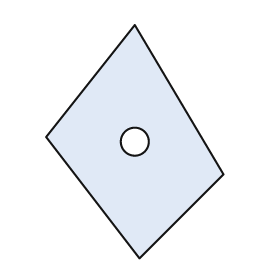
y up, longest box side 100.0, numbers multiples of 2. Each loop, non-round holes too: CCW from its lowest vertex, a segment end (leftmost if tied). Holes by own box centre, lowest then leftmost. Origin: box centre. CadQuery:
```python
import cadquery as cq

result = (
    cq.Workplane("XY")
    .moveTo(2.0, -50.0)
    .lineTo(38.0, -14.0)
    .lineTo(0.0, 50.0)
    .lineTo(-38.0, 2.0)
    .close()
    .moveTo(0.0, 0.0)
    .circle(6.0)
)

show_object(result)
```